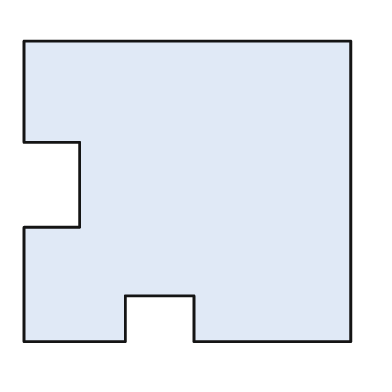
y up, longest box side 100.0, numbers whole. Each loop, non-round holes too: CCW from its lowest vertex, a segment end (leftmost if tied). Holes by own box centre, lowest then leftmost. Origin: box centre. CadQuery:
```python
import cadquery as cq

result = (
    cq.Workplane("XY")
    .moveTo(-50.0, -46.0)
    .lineTo(-19.0, -46.0)
    .lineTo(-19.0, -32.0)
    .lineTo(2.0, -32.0)
    .lineTo(2.0, -46.0)
    .lineTo(50.0, -46.0)
    .lineTo(50.0, 46.0)
    .lineTo(-50.0, 46.0)
    .lineTo(-50.0, 15.0)
    .lineTo(-33.0, 15.0)
    .lineTo(-33.0, -11.0)
    .lineTo(-50.0, -11.0)
    .close()
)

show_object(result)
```